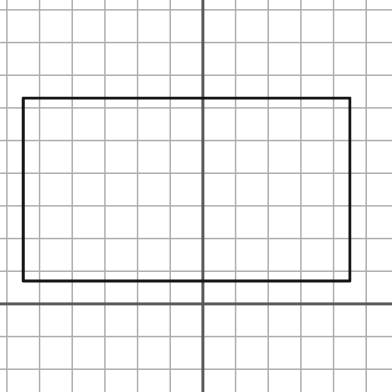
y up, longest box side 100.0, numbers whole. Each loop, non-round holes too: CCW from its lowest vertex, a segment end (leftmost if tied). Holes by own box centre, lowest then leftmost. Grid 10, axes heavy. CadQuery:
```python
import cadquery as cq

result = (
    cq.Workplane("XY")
    .moveTo(-55.0, 7.0)
    .lineTo(45.0, 7.0)
    .lineTo(45.0, 63.0)
    .lineTo(-55.0, 63.0)
    .close()
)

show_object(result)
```